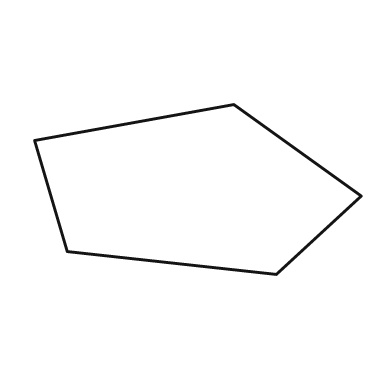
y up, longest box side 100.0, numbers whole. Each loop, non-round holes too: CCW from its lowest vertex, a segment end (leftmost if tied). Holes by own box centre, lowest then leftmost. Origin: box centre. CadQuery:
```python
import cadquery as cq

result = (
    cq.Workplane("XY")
    .moveTo(24.0, -26.0)
    .lineTo(50.0, -2.0)
    .lineTo(11.0, 26.0)
    .lineTo(-50.0, 15.0)
    .lineTo(-40.0, -19.0)
    .close()
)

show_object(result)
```